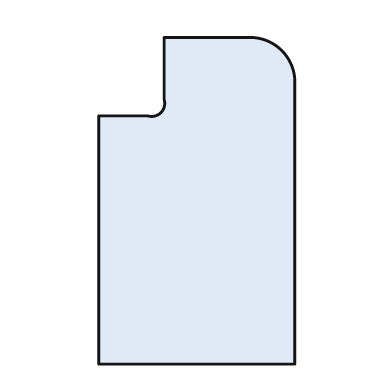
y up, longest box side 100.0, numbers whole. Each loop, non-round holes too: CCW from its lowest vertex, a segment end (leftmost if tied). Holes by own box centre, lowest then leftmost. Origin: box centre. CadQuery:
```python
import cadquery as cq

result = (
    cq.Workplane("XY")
    .moveTo(-30.0, -50.0)
    .lineTo(30.0, -50.0)
    .lineTo(30.0, 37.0)
    .threePointArc((26.0, 46.0), (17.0, 50.0))
    .lineTo(-10.0, 50.0)
    .lineTo(-10.0, 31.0)
    .threePointArc((-11.0, 27.0), (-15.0, 26.0))
    .lineTo(-30.0, 26.0)
    .close()
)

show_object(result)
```